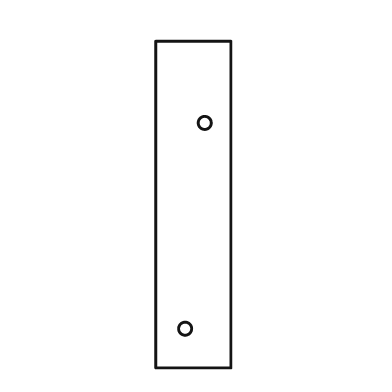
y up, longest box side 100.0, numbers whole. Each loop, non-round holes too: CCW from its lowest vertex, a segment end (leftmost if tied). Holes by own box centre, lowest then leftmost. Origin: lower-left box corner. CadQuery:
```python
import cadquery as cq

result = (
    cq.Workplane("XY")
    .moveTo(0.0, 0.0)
    .lineTo(23.0, 0.0)
    .lineTo(23.0, 100.0)
    .lineTo(0.0, 100.0)
    .close()
    .moveTo(9.0, 12.0)
    .circle(2.0)
    .moveTo(15.0, 75.0)
    .circle(2.0)
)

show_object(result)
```